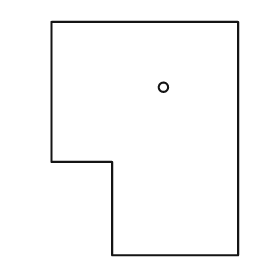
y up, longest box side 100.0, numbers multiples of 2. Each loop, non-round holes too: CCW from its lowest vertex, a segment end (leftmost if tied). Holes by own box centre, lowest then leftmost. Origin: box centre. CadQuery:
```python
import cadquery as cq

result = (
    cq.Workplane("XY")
    .moveTo(-14.0, -50.0)
    .lineTo(40.0, -50.0)
    .lineTo(40.0, 50.0)
    .lineTo(-40.0, 50.0)
    .lineTo(-40.0, -10.0)
    .lineTo(-14.0, -10.0)
    .close()
    .moveTo(8.0, 22.0)
    .circle(2.0)
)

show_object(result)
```